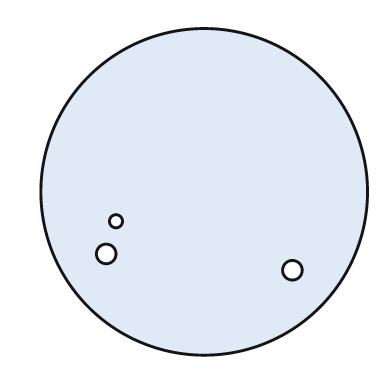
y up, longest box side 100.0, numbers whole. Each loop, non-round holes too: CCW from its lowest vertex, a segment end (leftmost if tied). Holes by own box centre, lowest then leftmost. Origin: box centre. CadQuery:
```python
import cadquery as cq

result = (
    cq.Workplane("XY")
    .moveTo(0.0, 0.0)
    .circle(50.0)
    .moveTo(27.0, -24.0)
    .circle(3.0)
    .moveTo(-30.0, -19.0)
    .circle(3.0)
    .moveTo(-27.0, -9.0)
    .circle(2.0)
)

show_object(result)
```